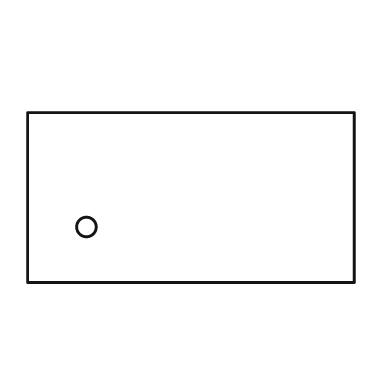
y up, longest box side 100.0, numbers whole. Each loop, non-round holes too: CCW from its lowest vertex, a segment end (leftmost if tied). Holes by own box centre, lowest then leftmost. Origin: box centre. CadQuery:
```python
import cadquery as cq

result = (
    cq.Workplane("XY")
    .moveTo(-50.0, -26.0)
    .lineTo(50.0, -26.0)
    .lineTo(50.0, 26.0)
    .lineTo(-50.0, 26.0)
    .close()
    .moveTo(-32.0, -9.0)
    .circle(3.0)
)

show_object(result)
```